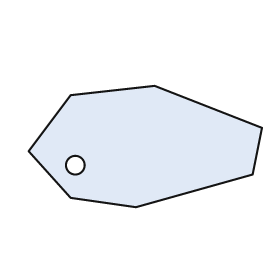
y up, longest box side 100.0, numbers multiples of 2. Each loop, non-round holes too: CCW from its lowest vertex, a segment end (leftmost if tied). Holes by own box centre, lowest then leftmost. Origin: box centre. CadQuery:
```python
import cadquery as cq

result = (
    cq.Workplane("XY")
    .moveTo(-4.0, -26.0)
    .lineTo(46.0, -12.0)
    .lineTo(50.0, 8.0)
    .lineTo(4.0, 26.0)
    .lineTo(-32.0, 22.0)
    .lineTo(-50.0, -2.0)
    .lineTo(-32.0, -22.0)
    .close()
    .moveTo(-30.0, -8.0)
    .circle(4.0)
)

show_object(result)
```